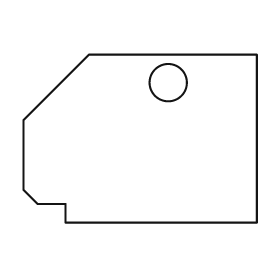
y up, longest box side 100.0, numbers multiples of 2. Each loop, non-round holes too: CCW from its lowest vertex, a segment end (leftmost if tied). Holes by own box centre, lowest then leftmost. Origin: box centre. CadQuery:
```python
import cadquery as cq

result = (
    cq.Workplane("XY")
    .moveTo(-32.0, -36.0)
    .lineTo(50.0, -36.0)
    .lineTo(50.0, 36.0)
    .lineTo(-22.0, 36.0)
    .lineTo(-50.0, 8.0)
    .lineTo(-50.0, -22.0)
    .lineTo(-44.0, -28.0)
    .lineTo(-32.0, -28.0)
    .close()
    .moveTo(12.0, 24.0)
    .circle(8.0)
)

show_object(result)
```